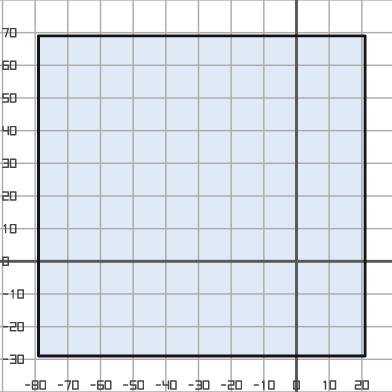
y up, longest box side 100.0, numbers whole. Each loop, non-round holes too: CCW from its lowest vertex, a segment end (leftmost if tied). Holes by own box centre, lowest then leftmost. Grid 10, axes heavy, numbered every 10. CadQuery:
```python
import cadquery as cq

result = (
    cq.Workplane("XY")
    .moveTo(-79.0, -29.0)
    .lineTo(21.0, -29.0)
    .lineTo(21.0, 69.0)
    .lineTo(-79.0, 69.0)
    .close()
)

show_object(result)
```